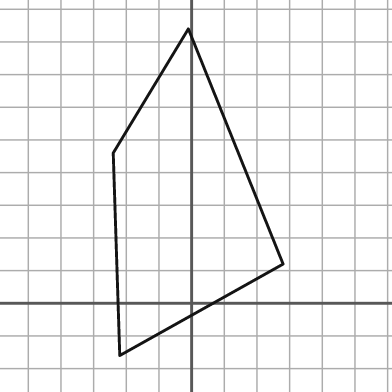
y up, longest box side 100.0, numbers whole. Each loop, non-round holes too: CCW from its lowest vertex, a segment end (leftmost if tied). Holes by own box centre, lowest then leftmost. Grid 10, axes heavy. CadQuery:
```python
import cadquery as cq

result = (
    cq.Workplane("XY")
    .moveTo(-22.0, -16.0)
    .lineTo(28.0, 12.0)
    .lineTo(-1.0, 84.0)
    .lineTo(-24.0, 46.0)
    .close()
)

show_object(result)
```